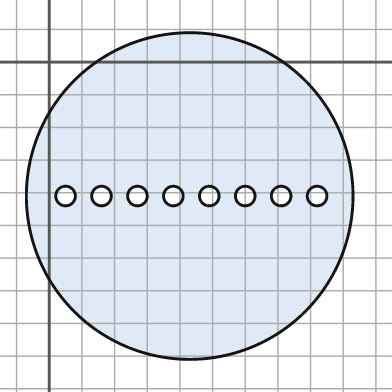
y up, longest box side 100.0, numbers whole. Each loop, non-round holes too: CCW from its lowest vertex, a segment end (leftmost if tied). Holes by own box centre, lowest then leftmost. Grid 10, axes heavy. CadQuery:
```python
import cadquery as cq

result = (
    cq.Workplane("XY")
    .moveTo(43.0, -41.0)
    .circle(50.0)
    .moveTo(5.0, -41.0)
    .circle(3.0)
    .moveTo(16.0, -41.0)
    .circle(3.0)
    .moveTo(27.0, -41.0)
    .circle(3.0)
    .moveTo(38.0, -41.0)
    .circle(3.0)
    .moveTo(49.0, -41.0)
    .circle(3.0)
    .moveTo(60.0, -41.0)
    .circle(3.0)
    .moveTo(71.0, -41.0)
    .circle(3.0)
    .moveTo(82.0, -41.0)
    .circle(3.0)
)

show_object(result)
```